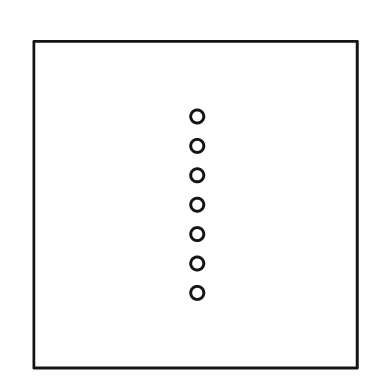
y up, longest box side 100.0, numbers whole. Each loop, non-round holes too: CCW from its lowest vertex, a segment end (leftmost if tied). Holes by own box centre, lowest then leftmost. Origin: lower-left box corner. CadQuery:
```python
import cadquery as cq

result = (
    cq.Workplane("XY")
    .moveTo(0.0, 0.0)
    .lineTo(99.0, 0.0)
    .lineTo(99.0, 100.0)
    .lineTo(0.0, 100.0)
    .close()
    .moveTo(50.0, 23.0)
    .circle(2.0)
    .moveTo(50.0, 32.0)
    .circle(2.0)
    .moveTo(50.0, 41.0)
    .circle(2.0)
    .moveTo(50.0, 50.0)
    .circle(2.0)
    .moveTo(50.0, 59.0)
    .circle(2.0)
    .moveTo(50.0, 68.0)
    .circle(2.0)
    .moveTo(50.0, 77.0)
    .circle(2.0)
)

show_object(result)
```